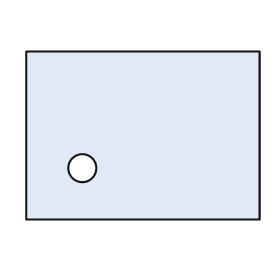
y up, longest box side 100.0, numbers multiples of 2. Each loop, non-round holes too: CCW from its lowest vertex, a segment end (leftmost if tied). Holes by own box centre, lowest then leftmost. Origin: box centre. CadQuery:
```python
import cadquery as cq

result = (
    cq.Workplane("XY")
    .moveTo(-50.0, -36.0)
    .lineTo(50.0, -36.0)
    .lineTo(50.0, 36.0)
    .lineTo(-50.0, 36.0)
    .close()
    .moveTo(-26.0, -14.0)
    .circle(6.0)
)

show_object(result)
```